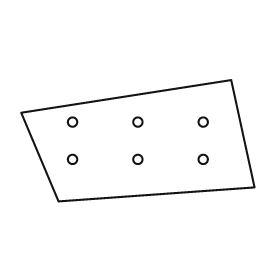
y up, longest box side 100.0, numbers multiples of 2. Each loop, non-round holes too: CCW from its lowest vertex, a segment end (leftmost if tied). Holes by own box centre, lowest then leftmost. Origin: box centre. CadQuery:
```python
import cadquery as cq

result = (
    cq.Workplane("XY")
    .moveTo(-34.0, -26.0)
    .lineTo(50.0, -20.0)
    .lineTo(40.0, 26.0)
    .lineTo(-50.0, 12.0)
    .close()
    .moveTo(-28.0, -8.0)
    .circle(2.0)
    .moveTo(0.0, -8.0)
    .circle(2.0)
    .moveTo(28.0, -8.0)
    .circle(2.0)
    .moveTo(-28.0, 8.0)
    .circle(2.0)
    .moveTo(0.0, 8.0)
    .circle(2.0)
    .moveTo(28.0, 8.0)
    .circle(2.0)
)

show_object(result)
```